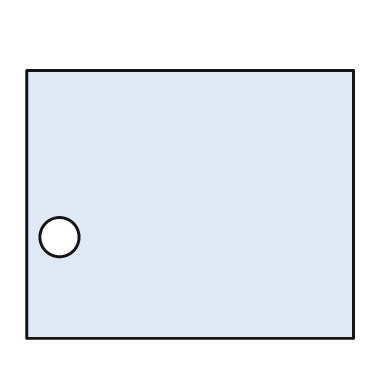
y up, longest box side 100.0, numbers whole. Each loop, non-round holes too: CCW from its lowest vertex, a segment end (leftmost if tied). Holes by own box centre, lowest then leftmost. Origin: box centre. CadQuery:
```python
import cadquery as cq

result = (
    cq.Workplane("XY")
    .moveTo(-50.0, -41.0)
    .lineTo(50.0, -41.0)
    .lineTo(50.0, 41.0)
    .lineTo(-50.0, 41.0)
    .close()
    .moveTo(-40.0, -10.0)
    .circle(6.0)
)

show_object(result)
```